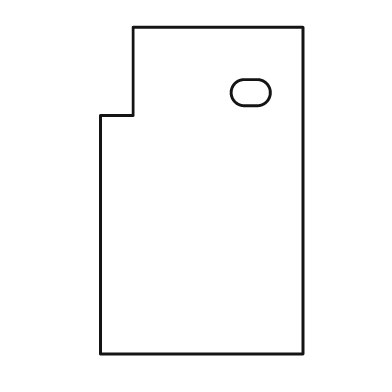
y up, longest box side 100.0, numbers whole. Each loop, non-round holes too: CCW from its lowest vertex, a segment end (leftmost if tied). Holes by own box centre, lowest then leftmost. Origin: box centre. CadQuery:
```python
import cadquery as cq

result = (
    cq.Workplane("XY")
    .moveTo(-31.0, -50.0)
    .lineTo(31.0, -50.0)
    .lineTo(31.0, 50.0)
    .lineTo(-21.0, 50.0)
    .lineTo(-21.0, 23.0)
    .lineTo(-31.0, 23.0)
    .close()
    .moveTo(13.0, 26.0)
    .lineTo(17.0, 26.0)
    .threePointArc((21.0, 30.0), (17.0, 34.0))
    .lineTo(13.0, 34.0)
    .threePointArc((9.0, 30.0), (13.0, 26.0))
    .close()
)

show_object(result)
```